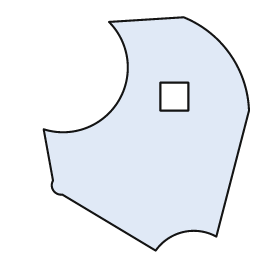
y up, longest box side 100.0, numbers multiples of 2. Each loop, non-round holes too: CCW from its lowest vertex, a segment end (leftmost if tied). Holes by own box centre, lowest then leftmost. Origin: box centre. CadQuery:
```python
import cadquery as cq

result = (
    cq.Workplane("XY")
    .moveTo(4.0, -50.0)
    .threePointArc((16.0, -42.0), (30.0, -44.0))
    .lineTo(44.0, 10.0)
    .threePointArc((36.0, 34.0), (16.0, 50.0))
    .lineTo(-16.0, 48.0)
    .threePointArc((-12.0, 14.0), (-44.0, 2.0))
    .lineTo(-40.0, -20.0)
    .threePointArc((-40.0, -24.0), (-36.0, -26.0))
    .close()
    .moveTo(6.0, 10.0)
    .lineTo(18.0, 10.0)
    .lineTo(18.0, 22.0)
    .lineTo(6.0, 22.0)
    .close()
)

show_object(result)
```